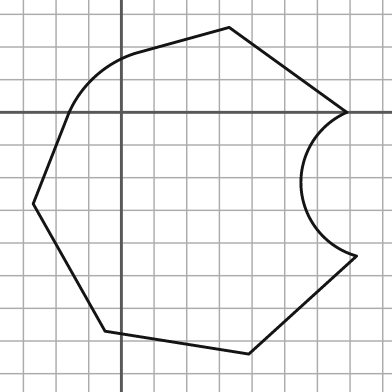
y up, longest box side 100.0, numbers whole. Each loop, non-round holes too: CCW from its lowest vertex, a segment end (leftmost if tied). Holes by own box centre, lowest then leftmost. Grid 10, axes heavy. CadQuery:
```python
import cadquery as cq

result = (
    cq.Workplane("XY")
    .moveTo(39.0, -74.0)
    .lineTo(72.0, -44.0)
    .threePointArc((55.0, -23.0), (69.0, 0.0))
    .lineTo(33.0, 26.0)
    .lineTo(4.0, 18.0)
    .threePointArc((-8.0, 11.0), (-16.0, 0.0))
    .lineTo(-27.0, -28.0)
    .lineTo(-5.0, -67.0)
    .close()
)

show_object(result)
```